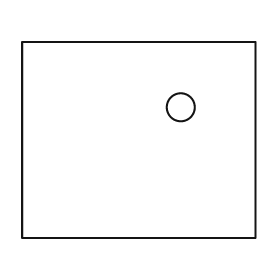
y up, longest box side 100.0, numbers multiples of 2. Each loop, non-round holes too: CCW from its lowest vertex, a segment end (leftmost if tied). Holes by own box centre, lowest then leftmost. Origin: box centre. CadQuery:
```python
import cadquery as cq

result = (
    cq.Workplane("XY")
    .moveTo(-50.0, -42.0)
    .lineTo(50.0, -42.0)
    .lineTo(50.0, 42.0)
    .lineTo(-50.0, 42.0)
    .close()
    .moveTo(18.0, 14.0)
    .circle(6.0)
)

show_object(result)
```